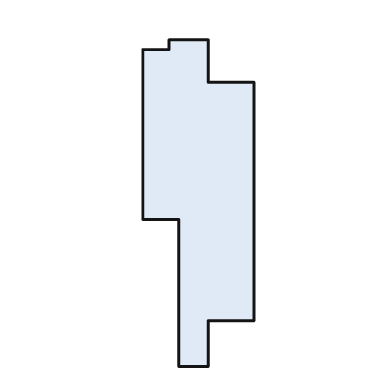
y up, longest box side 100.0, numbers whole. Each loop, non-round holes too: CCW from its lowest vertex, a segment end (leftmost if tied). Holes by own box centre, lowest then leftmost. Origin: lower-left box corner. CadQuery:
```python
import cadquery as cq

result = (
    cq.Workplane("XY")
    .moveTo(11.0, 0.0)
    .lineTo(20.0, 0.0)
    .lineTo(20.0, 14.0)
    .lineTo(34.0, 14.0)
    .lineTo(34.0, 87.0)
    .lineTo(20.0, 87.0)
    .lineTo(20.0, 100.0)
    .lineTo(8.0, 100.0)
    .lineTo(8.0, 97.0)
    .lineTo(0.0, 97.0)
    .lineTo(0.0, 45.0)
    .lineTo(11.0, 45.0)
    .close()
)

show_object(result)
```